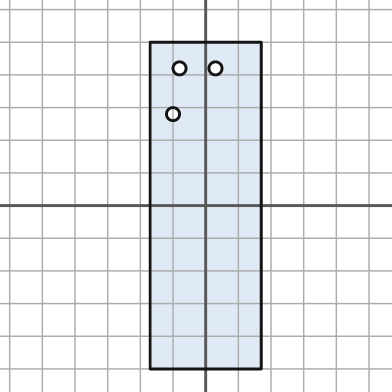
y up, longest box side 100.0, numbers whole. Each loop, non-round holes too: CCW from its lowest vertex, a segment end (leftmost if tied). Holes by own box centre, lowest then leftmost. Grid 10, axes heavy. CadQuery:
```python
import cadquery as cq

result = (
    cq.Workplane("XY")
    .moveTo(-17.0, -50.0)
    .lineTo(17.0, -50.0)
    .lineTo(17.0, 50.0)
    .lineTo(-17.0, 50.0)
    .close()
    .moveTo(-10.0, 28.0)
    .circle(2.0)
    .moveTo(-8.0, 42.0)
    .circle(2.0)
    .moveTo(3.0, 42.0)
    .circle(2.0)
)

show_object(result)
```